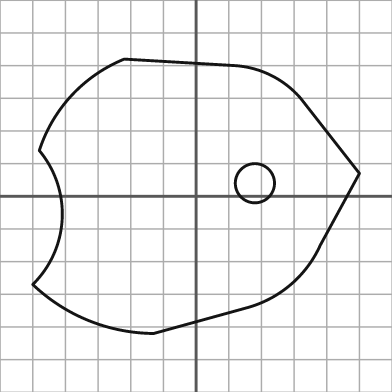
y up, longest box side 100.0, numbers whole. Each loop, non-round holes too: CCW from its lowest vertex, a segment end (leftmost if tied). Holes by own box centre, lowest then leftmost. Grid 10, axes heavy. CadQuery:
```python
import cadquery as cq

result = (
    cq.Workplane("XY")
    .moveTo(-13.0, -42.0)
    .lineTo(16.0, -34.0)
    .threePointArc((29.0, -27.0), (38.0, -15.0))
    .lineTo(50.0, 7.0)
    .lineTo(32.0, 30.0)
    .threePointArc((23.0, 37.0), (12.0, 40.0))
    .lineTo(-22.0, 42.0)
    .threePointArc((-38.0, 31.0), (-48.0, 14.0))
    .threePointArc((-41.0, -7.0), (-50.0, -27.0))
    .threePointArc((-33.0, -38.0), (-13.0, -42.0))
    .close()
    .moveTo(18.0, 4.0)
    .circle(6.0)
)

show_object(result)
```